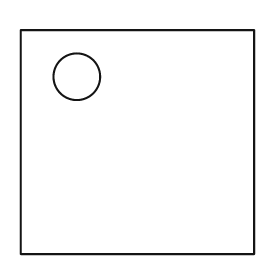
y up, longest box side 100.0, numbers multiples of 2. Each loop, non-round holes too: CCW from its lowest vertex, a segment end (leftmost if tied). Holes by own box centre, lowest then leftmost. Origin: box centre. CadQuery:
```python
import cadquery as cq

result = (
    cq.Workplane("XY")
    .moveTo(-50.0, -48.0)
    .lineTo(50.0, -48.0)
    .lineTo(50.0, 48.0)
    .lineTo(-50.0, 48.0)
    .close()
    .moveTo(-26.0, 28.0)
    .circle(10.0)
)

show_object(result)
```